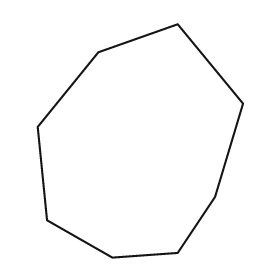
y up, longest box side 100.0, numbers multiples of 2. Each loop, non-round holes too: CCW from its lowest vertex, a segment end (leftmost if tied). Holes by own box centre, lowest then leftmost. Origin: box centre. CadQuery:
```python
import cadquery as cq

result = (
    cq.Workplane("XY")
    .moveTo(-12.0, -50.0)
    .lineTo(16.0, -48.0)
    .lineTo(32.0, -24.0)
    .lineTo(44.0, 16.0)
    .lineTo(16.0, 50.0)
    .lineTo(-18.0, 38.0)
    .lineTo(-44.0, 6.0)
    .lineTo(-40.0, -34.0)
    .close()
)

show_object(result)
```